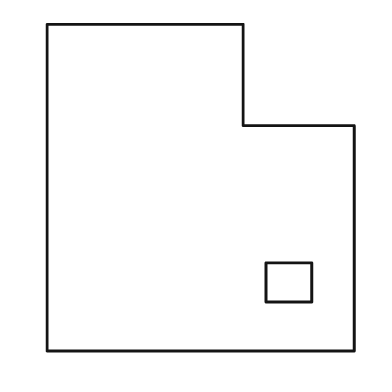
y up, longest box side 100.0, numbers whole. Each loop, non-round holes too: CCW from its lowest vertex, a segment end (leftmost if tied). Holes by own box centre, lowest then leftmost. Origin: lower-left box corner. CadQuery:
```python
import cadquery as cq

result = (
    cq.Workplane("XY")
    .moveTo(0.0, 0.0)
    .lineTo(94.0, 0.0)
    .lineTo(94.0, 69.0)
    .lineTo(60.0, 69.0)
    .lineTo(60.0, 100.0)
    .lineTo(0.0, 100.0)
    .close()
    .moveTo(67.0, 15.0)
    .lineTo(81.0, 15.0)
    .lineTo(81.0, 27.0)
    .lineTo(67.0, 27.0)
    .close()
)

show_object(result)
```